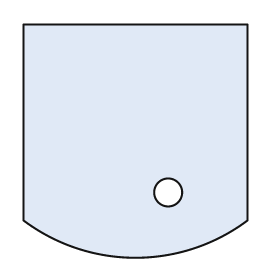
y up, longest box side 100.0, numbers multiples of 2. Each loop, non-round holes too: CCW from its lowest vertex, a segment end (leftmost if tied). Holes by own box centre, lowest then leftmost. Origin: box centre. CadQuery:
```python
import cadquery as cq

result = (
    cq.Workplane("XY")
    .moveTo(-48.0, -34.0)
    .threePointArc((0.0, -50.0), (48.0, -34.0))
    .lineTo(48.0, 50.0)
    .lineTo(-48.0, 50.0)
    .close()
    .moveTo(14.0, -22.0)
    .circle(6.0)
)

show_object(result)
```